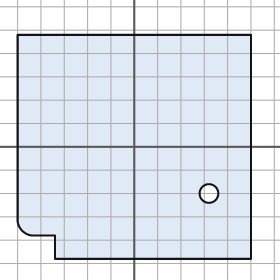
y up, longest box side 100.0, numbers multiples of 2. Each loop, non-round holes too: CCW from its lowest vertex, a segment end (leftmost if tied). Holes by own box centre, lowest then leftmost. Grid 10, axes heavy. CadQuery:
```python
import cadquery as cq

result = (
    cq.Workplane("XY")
    .moveTo(-34.0, -48.0)
    .lineTo(50.0, -48.0)
    .lineTo(50.0, 48.0)
    .lineTo(-50.0, 48.0)
    .lineTo(-50.0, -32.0)
    .threePointArc((-48.0, -36.0), (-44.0, -38.0))
    .lineTo(-34.0, -38.0)
    .close()
    .moveTo(32.0, -20.0)
    .circle(4.0)
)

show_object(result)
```